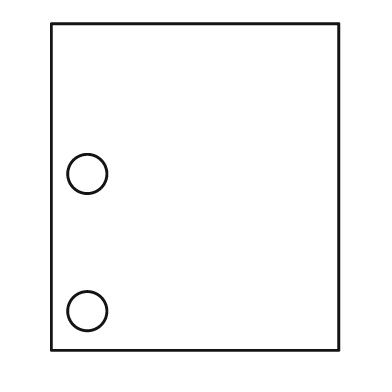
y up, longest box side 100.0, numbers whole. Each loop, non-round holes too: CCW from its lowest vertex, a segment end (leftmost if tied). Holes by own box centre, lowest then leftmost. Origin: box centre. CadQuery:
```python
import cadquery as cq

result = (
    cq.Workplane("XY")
    .moveTo(-44.0, -50.0)
    .lineTo(44.0, -50.0)
    .lineTo(44.0, 50.0)
    .lineTo(-44.0, 50.0)
    .close()
    .moveTo(-33.0, -38.0)
    .circle(6.0)
    .moveTo(-33.0, 4.0)
    .circle(6.0)
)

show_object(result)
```